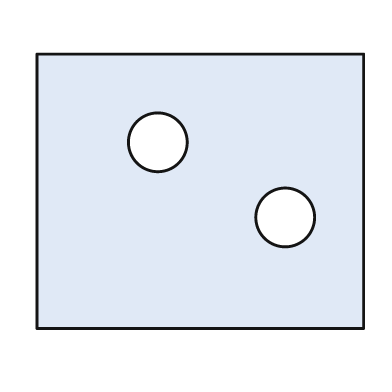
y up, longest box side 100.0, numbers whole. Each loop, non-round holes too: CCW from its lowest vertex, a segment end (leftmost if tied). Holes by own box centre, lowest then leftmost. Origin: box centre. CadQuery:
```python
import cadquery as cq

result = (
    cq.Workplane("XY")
    .moveTo(-50.0, -42.0)
    .lineTo(50.0, -42.0)
    .lineTo(50.0, 42.0)
    .lineTo(-50.0, 42.0)
    .close()
    .moveTo(26.0, -8.0)
    .circle(9.0)
    .moveTo(-13.0, 15.0)
    .circle(9.0)
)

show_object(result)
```